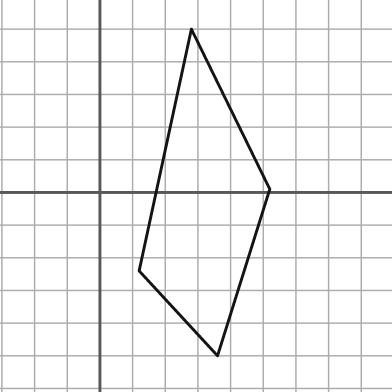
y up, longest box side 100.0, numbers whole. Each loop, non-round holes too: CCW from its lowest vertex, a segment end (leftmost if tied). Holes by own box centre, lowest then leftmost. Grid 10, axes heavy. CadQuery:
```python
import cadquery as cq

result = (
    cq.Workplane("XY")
    .moveTo(36.0, -50.0)
    .lineTo(52.0, 1.0)
    .lineTo(28.0, 50.0)
    .lineTo(12.0, -24.0)
    .close()
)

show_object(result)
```